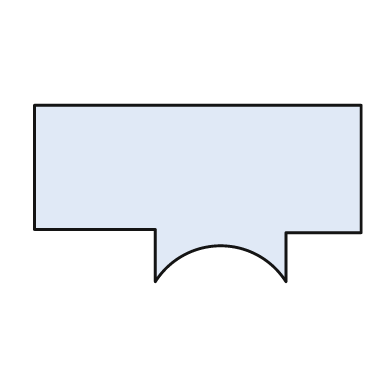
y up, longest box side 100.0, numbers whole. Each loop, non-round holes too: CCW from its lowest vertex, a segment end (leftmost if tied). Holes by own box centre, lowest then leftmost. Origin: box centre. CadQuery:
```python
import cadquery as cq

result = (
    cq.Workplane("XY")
    .moveTo(-13.0, -27.0)
    .threePointArc((7.0, -16.0), (27.0, -27.0))
    .lineTo(27.0, -12.0)
    .lineTo(50.0, -12.0)
    .lineTo(50.0, 27.0)
    .lineTo(-50.0, 27.0)
    .lineTo(-50.0, -11.0)
    .lineTo(-13.0, -11.0)
    .close()
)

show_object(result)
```